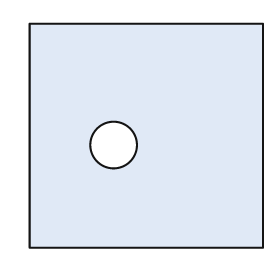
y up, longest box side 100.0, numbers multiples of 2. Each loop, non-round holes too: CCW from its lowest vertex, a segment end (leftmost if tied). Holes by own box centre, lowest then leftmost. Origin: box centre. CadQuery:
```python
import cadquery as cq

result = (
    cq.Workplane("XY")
    .moveTo(-50.0, -48.0)
    .lineTo(50.0, -48.0)
    .lineTo(50.0, 48.0)
    .lineTo(-50.0, 48.0)
    .close()
    .moveTo(-14.0, -4.0)
    .circle(10.0)
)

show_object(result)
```